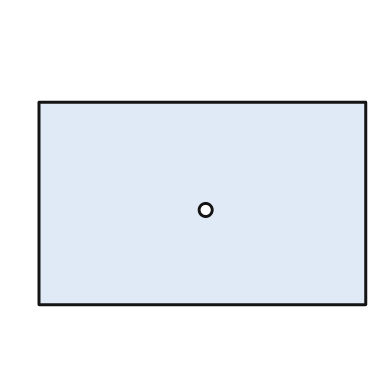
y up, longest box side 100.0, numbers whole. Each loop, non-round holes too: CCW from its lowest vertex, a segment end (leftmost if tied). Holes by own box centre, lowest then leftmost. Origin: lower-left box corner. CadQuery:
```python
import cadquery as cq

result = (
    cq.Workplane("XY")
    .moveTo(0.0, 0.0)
    .lineTo(100.0, 0.0)
    .lineTo(100.0, 62.0)
    .lineTo(0.0, 62.0)
    .close()
    .moveTo(51.0, 29.0)
    .circle(2.0)
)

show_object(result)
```